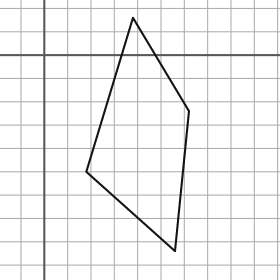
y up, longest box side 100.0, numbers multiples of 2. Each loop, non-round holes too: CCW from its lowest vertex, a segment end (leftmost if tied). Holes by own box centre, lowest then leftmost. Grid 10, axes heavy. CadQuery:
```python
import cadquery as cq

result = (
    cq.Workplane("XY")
    .moveTo(56.0, -84.0)
    .lineTo(62.0, -24.0)
    .lineTo(38.0, 16.0)
    .lineTo(18.0, -50.0)
    .close()
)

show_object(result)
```